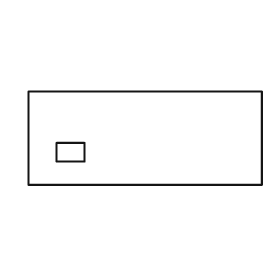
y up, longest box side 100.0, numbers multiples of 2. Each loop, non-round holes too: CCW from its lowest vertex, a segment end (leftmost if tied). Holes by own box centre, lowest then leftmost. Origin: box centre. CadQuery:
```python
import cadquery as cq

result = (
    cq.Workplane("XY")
    .moveTo(-50.0, -20.0)
    .lineTo(50.0, -20.0)
    .lineTo(50.0, 20.0)
    .lineTo(-50.0, 20.0)
    .close()
    .moveTo(-38.0, -10.0)
    .lineTo(-26.0, -10.0)
    .lineTo(-26.0, -2.0)
    .lineTo(-38.0, -2.0)
    .close()
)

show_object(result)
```